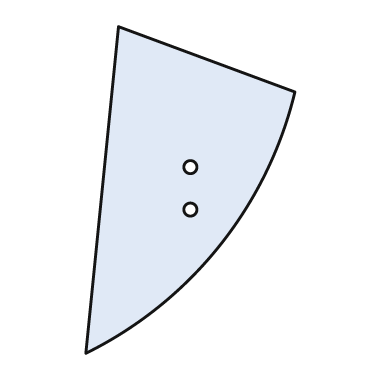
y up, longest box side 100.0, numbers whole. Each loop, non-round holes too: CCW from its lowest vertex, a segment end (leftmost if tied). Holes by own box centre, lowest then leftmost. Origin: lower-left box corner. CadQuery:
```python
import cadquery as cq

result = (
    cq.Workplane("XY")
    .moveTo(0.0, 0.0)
    .threePointArc((41.0, 33.0), (64.0, 80.0))
    .lineTo(10.0, 100.0)
    .close()
    .moveTo(32.0, 44.0)
    .circle(2.0)
    .moveTo(32.0, 57.0)
    .circle(2.0)
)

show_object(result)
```